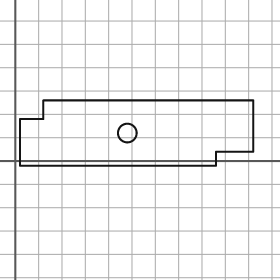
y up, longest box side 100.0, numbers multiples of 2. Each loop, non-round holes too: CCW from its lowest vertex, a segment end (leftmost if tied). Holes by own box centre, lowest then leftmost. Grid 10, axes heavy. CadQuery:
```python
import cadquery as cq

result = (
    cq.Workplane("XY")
    .moveTo(2.0, -2.0)
    .lineTo(86.0, -2.0)
    .lineTo(86.0, 4.0)
    .lineTo(102.0, 4.0)
    .lineTo(102.0, 26.0)
    .lineTo(12.0, 26.0)
    .lineTo(12.0, 18.0)
    .lineTo(2.0, 18.0)
    .close()
    .moveTo(48.0, 12.0)
    .circle(4.0)
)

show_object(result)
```